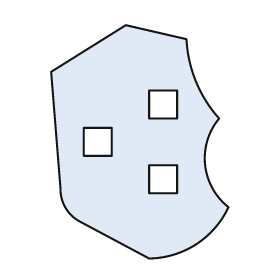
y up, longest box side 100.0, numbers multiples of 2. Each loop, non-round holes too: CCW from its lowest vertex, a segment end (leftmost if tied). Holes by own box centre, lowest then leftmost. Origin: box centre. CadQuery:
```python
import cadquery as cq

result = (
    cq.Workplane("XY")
    .moveTo(4.0, -50.0)
    .threePointArc((24.0, -44.0), (38.0, -28.0))
    .threePointArc((28.0, -10.0), (34.0, 10.0))
    .threePointArc((24.0, 26.0), (20.0, 44.0))
    .lineTo(-6.0, 50.0)
    .lineTo(-38.0, 30.0)
    .lineTo(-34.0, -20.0)
    .threePointArc((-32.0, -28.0), (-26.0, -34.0))
    .close()
    .moveTo(4.0, -22.0)
    .lineTo(16.0, -22.0)
    .lineTo(16.0, -10.0)
    .lineTo(4.0, -10.0)
    .close()
    .moveTo(-24.0, -6.0)
    .lineTo(-12.0, -6.0)
    .lineTo(-12.0, 6.0)
    .lineTo(-24.0, 6.0)
    .close()
    .moveTo(4.0, 10.0)
    .lineTo(16.0, 10.0)
    .lineTo(16.0, 22.0)
    .lineTo(4.0, 22.0)
    .close()
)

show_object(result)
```